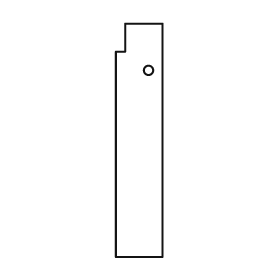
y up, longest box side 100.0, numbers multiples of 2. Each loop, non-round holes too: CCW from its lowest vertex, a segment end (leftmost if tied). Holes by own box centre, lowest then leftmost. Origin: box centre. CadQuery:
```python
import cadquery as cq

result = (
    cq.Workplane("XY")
    .moveTo(-10.0, -50.0)
    .lineTo(10.0, -50.0)
    .lineTo(10.0, 50.0)
    .lineTo(-6.0, 50.0)
    .lineTo(-6.0, 38.0)
    .lineTo(-10.0, 38.0)
    .close()
    .moveTo(4.0, 30.0)
    .circle(2.0)
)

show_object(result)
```